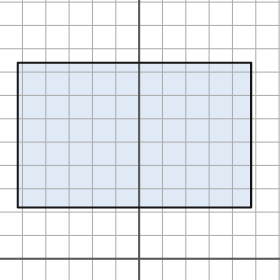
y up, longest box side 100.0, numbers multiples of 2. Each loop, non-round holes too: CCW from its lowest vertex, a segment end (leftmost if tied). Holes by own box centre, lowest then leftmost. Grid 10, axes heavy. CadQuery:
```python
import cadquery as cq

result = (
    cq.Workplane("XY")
    .moveTo(-52.0, 22.0)
    .lineTo(48.0, 22.0)
    .lineTo(48.0, 84.0)
    .lineTo(-52.0, 84.0)
    .close()
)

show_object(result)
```